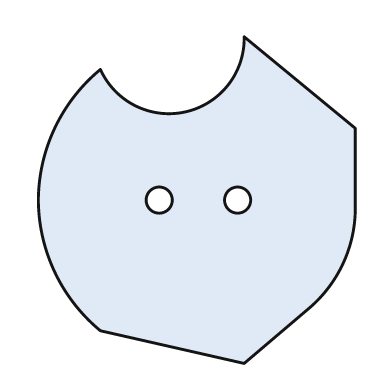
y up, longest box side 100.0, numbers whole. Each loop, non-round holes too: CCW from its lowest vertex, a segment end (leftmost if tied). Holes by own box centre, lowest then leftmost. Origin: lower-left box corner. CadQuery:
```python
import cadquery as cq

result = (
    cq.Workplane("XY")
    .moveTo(63.0, 0.0)
    .lineTo(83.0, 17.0)
    .threePointArc((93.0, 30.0), (97.0, 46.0))
    .lineTo(97.0, 72.0)
    .lineTo(63.0, 100.0)
    .threePointArc((45.0, 77.0), (19.0, 90.0))
    .threePointArc((5.0, 72.0), (0.0, 50.0))
    .threePointArc((5.0, 28.0), (19.0, 10.0))
    .close()
    .moveTo(37.0, 50.0)
    .circle(4.0)
    .moveTo(61.0, 50.0)
    .circle(4.0)
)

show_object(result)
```